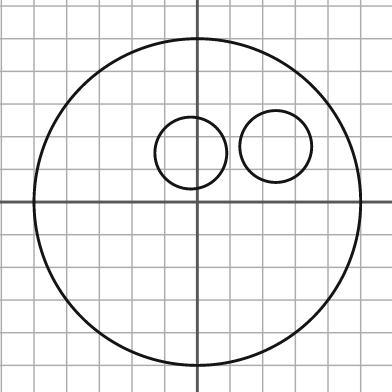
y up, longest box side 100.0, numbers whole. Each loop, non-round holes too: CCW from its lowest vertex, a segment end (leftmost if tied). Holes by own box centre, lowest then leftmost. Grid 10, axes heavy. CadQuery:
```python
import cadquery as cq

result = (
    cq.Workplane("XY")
    .moveTo(0.0, 0.0)
    .circle(50.0)
    .moveTo(-2.0, 15.0)
    .circle(11.0)
    .moveTo(24.0, 17.0)
    .circle(11.0)
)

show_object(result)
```